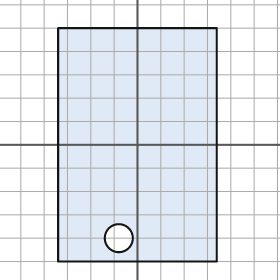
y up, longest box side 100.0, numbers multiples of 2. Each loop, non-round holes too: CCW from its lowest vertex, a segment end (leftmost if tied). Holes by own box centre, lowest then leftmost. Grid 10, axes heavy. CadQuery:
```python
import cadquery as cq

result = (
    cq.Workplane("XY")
    .moveTo(-34.0, -50.0)
    .lineTo(34.0, -50.0)
    .lineTo(34.0, 50.0)
    .lineTo(-34.0, 50.0)
    .close()
    .moveTo(-8.0, -40.0)
    .circle(6.0)
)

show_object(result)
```